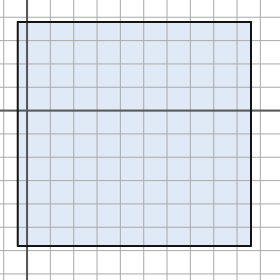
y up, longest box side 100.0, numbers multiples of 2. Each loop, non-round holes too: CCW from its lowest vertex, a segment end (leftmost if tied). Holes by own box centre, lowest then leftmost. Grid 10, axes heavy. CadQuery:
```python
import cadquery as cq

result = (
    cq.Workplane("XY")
    .moveTo(-4.0, -58.0)
    .lineTo(96.0, -58.0)
    .lineTo(96.0, 38.0)
    .lineTo(-4.0, 38.0)
    .close()
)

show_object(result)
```